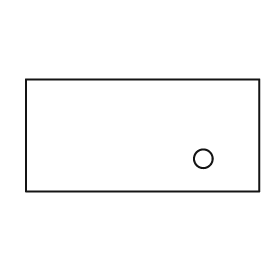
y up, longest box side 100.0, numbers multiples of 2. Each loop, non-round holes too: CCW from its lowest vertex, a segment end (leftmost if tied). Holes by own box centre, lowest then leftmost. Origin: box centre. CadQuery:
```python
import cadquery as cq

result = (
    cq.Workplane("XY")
    .moveTo(-50.0, -24.0)
    .lineTo(50.0, -24.0)
    .lineTo(50.0, 24.0)
    .lineTo(-50.0, 24.0)
    .close()
    .moveTo(26.0, -10.0)
    .circle(4.0)
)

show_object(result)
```